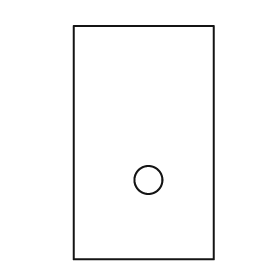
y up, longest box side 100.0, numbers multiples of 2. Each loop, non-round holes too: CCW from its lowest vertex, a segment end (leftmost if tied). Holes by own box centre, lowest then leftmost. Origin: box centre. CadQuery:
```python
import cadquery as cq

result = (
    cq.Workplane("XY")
    .moveTo(-30.0, -50.0)
    .lineTo(30.0, -50.0)
    .lineTo(30.0, 50.0)
    .lineTo(-30.0, 50.0)
    .close()
    .moveTo(2.0, -16.0)
    .circle(6.0)
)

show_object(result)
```